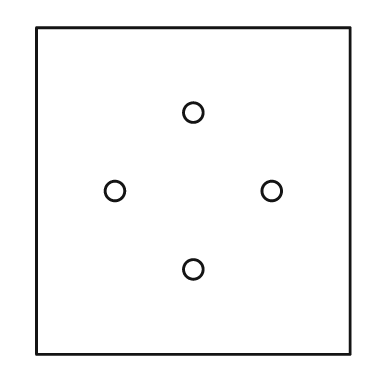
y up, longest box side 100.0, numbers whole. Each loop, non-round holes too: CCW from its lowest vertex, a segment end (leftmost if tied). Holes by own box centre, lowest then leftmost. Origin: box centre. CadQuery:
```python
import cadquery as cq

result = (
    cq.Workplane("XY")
    .moveTo(-48.0, -50.0)
    .lineTo(48.0, -50.0)
    .lineTo(48.0, 50.0)
    .lineTo(-48.0, 50.0)
    .close()
    .moveTo(0.0, -24.0)
    .circle(3.0)
    .moveTo(-24.0, 0.0)
    .circle(3.0)
    .moveTo(24.0, 0.0)
    .circle(3.0)
    .moveTo(0.0, 24.0)
    .circle(3.0)
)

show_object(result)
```